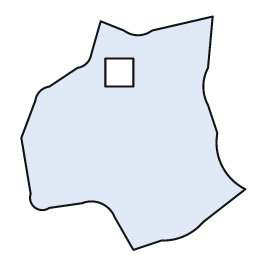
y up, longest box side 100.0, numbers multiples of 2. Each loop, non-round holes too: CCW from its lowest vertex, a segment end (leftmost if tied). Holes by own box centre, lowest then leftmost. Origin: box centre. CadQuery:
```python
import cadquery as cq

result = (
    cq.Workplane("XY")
    .moveTo(0.0, -50.0)
    .lineTo(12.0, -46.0)
    .threePointArc((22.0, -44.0), (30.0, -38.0))
    .lineTo(48.0, -24.0)
    .threePointArc((38.0, -14.0), (36.0, 0.0))
    .lineTo(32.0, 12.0)
    .threePointArc((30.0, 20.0), (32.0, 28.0))
    .lineTo(34.0, 50.0)
    .lineTo(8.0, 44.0)
    .threePointArc((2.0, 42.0), (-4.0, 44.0))
    .lineTo(-14.0, 48.0)
    .lineTo(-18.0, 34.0)
    .threePointArc((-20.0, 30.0), (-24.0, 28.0))
    .lineTo(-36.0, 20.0)
    .threePointArc((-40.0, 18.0), (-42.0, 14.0))
    .lineTo(-48.0, -2.0)
    .lineTo(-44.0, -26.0)
    .threePointArc((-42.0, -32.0), (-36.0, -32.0))
    .lineTo(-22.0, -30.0)
    .threePointArc((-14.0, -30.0), (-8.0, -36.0))
    .close()
    .moveTo(-12.0, 20.0)
    .lineTo(0.0, 20.0)
    .lineTo(0.0, 32.0)
    .lineTo(-12.0, 32.0)
    .close()
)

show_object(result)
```